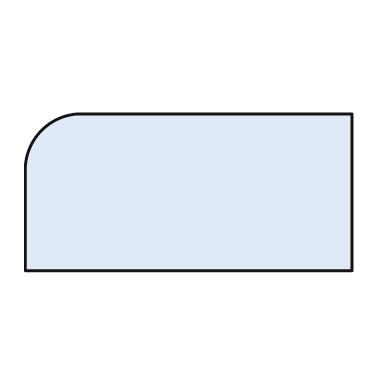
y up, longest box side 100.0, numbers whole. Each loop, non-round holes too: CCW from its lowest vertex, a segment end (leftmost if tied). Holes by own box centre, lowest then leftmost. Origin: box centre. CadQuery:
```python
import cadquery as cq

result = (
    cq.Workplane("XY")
    .moveTo(-50.0, -24.0)
    .lineTo(50.0, -24.0)
    .lineTo(50.0, 24.0)
    .lineTo(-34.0, 24.0)
    .threePointArc((-45.0, 19.0), (-50.0, 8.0))
    .close()
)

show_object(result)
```